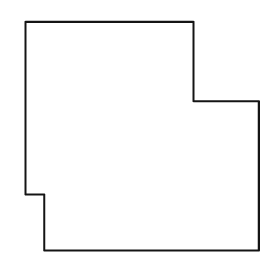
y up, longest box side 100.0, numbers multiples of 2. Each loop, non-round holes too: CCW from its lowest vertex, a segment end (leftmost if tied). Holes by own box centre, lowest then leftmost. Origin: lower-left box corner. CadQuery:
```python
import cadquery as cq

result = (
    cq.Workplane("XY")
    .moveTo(8.0, 0.0)
    .lineTo(100.0, 0.0)
    .lineTo(100.0, 64.0)
    .lineTo(72.0, 64.0)
    .lineTo(72.0, 98.0)
    .lineTo(0.0, 98.0)
    .lineTo(0.0, 24.0)
    .lineTo(8.0, 24.0)
    .close()
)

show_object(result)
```